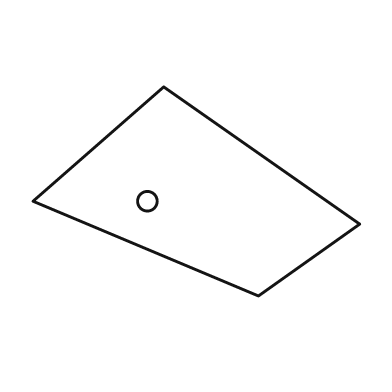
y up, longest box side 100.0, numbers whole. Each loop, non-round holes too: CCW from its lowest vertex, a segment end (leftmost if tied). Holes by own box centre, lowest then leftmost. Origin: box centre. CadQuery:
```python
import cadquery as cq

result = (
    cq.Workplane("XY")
    .moveTo(19.0, -32.0)
    .lineTo(50.0, -10.0)
    .lineTo(-10.0, 32.0)
    .lineTo(-50.0, -3.0)
    .close()
    .moveTo(-15.0, -3.0)
    .circle(3.0)
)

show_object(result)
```